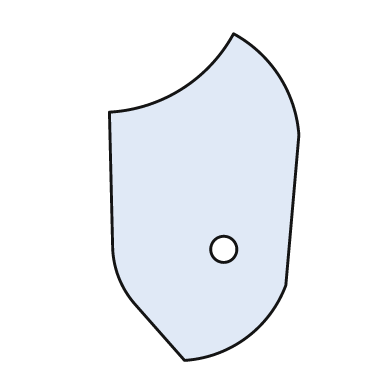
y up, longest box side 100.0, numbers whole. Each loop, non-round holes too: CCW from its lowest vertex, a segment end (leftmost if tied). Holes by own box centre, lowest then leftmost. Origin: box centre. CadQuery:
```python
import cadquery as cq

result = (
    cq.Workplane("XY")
    .moveTo(-6.0, -50.0)
    .threePointArc((13.0, -43.0), (25.0, -27.0))
    .lineTo(29.0, 19.0)
    .threePointArc((23.0, 37.0), (9.0, 50.0))
    .threePointArc((-7.0, 33.0), (-29.0, 26.0))
    .lineTo(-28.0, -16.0)
    .threePointArc((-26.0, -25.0), (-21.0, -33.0))
    .close()
    .moveTo(6.0, -16.0)
    .circle(4.0)
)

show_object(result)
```